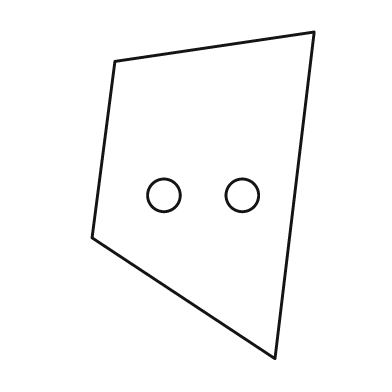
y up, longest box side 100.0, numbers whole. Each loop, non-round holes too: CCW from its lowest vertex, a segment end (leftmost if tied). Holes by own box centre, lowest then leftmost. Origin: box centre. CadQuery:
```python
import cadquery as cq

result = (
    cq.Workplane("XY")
    .moveTo(22.0, -50.0)
    .lineTo(34.0, 50.0)
    .lineTo(-27.0, 41.0)
    .lineTo(-34.0, -13.0)
    .close()
    .moveTo(-12.0, 0.0)
    .circle(5.0)
    .moveTo(12.0, 0.0)
    .circle(5.0)
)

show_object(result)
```